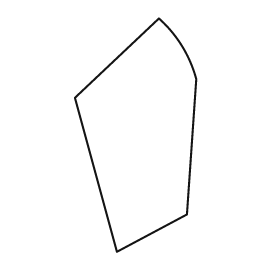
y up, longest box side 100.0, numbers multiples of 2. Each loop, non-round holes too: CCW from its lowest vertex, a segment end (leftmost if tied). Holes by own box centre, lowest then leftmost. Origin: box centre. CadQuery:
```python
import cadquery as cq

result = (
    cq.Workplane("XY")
    .moveTo(-8.0, -50.0)
    .lineTo(22.0, -34.0)
    .lineTo(26.0, 24.0)
    .threePointArc((20.0, 38.0), (10.0, 50.0))
    .lineTo(-26.0, 16.0)
    .close()
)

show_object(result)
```